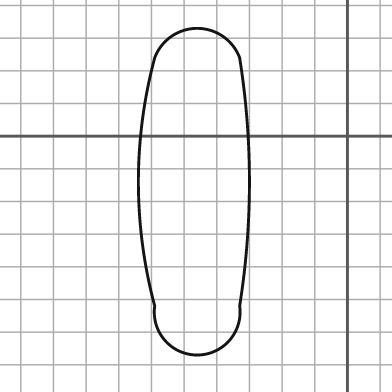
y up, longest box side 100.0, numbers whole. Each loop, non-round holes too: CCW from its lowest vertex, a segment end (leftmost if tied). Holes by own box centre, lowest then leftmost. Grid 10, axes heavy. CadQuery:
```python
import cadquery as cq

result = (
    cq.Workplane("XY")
    .moveTo(-59.0, -52.0)
    .threePointArc((-46.0, -67.0), (-33.0, -52.0))
    .threePointArc((-30.0, -14.0), (-33.0, 24.0))
    .threePointArc((-46.0, 33.0), (-59.0, 24.0))
    .threePointArc((-64.0, -14.0), (-59.0, -52.0))
    .close()
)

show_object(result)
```